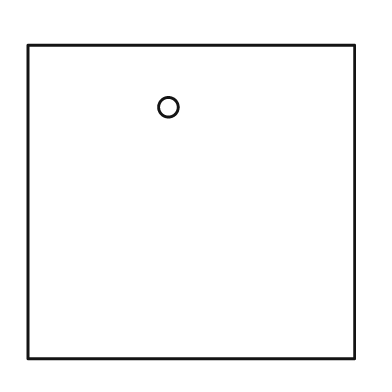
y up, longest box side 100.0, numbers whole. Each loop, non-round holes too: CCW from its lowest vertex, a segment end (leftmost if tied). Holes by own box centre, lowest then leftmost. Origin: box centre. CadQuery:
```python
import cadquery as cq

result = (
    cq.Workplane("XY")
    .moveTo(-50.0, -48.0)
    .lineTo(50.0, -48.0)
    .lineTo(50.0, 48.0)
    .lineTo(-50.0, 48.0)
    .close()
    .moveTo(-7.0, 29.0)
    .circle(3.0)
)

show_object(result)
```